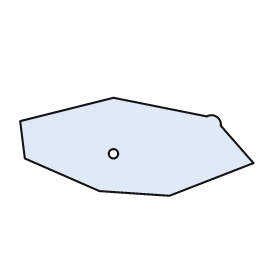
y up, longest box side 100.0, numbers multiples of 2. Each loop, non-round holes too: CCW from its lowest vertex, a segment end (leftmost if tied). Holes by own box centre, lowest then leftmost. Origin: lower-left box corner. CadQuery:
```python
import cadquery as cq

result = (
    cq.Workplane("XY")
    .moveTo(64.0, 0.0)
    .lineTo(100.0, 14.0)
    .lineTo(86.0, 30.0)
    .threePointArc((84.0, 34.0), (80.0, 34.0))
    .lineTo(40.0, 42.0)
    .lineTo(0.0, 32.0)
    .lineTo(2.0, 16.0)
    .lineTo(34.0, 2.0)
    .close()
    .moveTo(40.0, 18.0)
    .circle(2.0)
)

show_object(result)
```